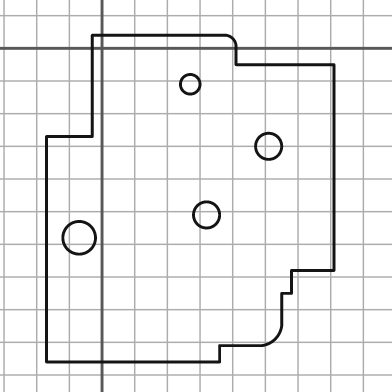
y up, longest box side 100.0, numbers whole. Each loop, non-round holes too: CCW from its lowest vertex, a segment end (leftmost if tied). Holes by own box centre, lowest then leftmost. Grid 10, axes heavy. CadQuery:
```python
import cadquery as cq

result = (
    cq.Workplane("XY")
    .moveTo(-17.0, -96.0)
    .lineTo(36.0, -96.0)
    .lineTo(36.0, -91.0)
    .lineTo(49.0, -91.0)
    .threePointArc((53.0, -89.0), (55.0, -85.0))
    .lineTo(55.0, -75.0)
    .lineTo(58.0, -75.0)
    .lineTo(58.0, -68.0)
    .lineTo(71.0, -68.0)
    .lineTo(71.0, -5.0)
    .lineTo(41.0, -5.0)
    .lineTo(41.0, 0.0)
    .threePointArc((40.0, 3.0), (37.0, 4.0))
    .lineTo(-3.0, 4.0)
    .lineTo(-3.0, -27.0)
    .lineTo(-17.0, -27.0)
    .close()
    .moveTo(-7.0, -58.0)
    .circle(5.0)
    .moveTo(32.0, -51.0)
    .circle(4.0)
    .moveTo(51.0, -30.0)
    .circle(4.0)
    .moveTo(27.0, -11.0)
    .circle(3.0)
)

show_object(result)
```